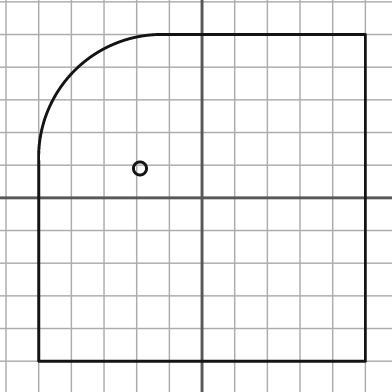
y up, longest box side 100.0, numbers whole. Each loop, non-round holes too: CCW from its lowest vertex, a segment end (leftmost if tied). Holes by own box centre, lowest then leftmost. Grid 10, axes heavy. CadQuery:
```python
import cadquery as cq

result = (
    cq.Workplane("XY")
    .moveTo(-50.0, -50.0)
    .lineTo(50.0, -50.0)
    .lineTo(50.0, 50.0)
    .lineTo(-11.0, 50.0)
    .threePointArc((-39.0, 39.0), (-50.0, 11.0))
    .close()
    .moveTo(-19.0, 9.0)
    .circle(2.0)
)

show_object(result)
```